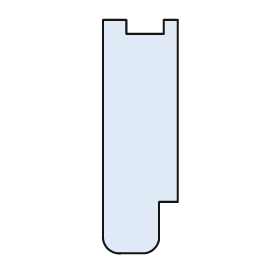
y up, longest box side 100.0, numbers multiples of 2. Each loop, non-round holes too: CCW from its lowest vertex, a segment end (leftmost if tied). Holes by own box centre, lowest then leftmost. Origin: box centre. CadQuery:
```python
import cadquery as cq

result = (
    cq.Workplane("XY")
    .moveTo(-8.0, -50.0)
    .lineTo(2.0, -50.0)
    .threePointArc((6.0, -48.0), (8.0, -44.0))
    .lineTo(8.0, -28.0)
    .lineTo(16.0, -28.0)
    .lineTo(16.0, 50.0)
    .lineTo(10.0, 50.0)
    .lineTo(10.0, 44.0)
    .lineTo(-6.0, 44.0)
    .lineTo(-6.0, 50.0)
    .lineTo(-16.0, 50.0)
    .lineTo(-16.0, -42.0)
    .threePointArc((-14.0, -48.0), (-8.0, -50.0))
    .close()
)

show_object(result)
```